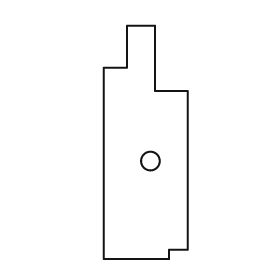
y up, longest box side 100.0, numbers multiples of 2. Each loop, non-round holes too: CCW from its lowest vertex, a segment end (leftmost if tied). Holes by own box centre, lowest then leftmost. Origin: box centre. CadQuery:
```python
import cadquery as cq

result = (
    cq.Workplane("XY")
    .moveTo(-18.0, -50.0)
    .lineTo(10.0, -50.0)
    .lineTo(10.0, -46.0)
    .lineTo(18.0, -46.0)
    .lineTo(18.0, 22.0)
    .lineTo(4.0, 22.0)
    .lineTo(4.0, 50.0)
    .lineTo(-8.0, 50.0)
    .lineTo(-8.0, 32.0)
    .lineTo(-18.0, 32.0)
    .close()
    .moveTo(2.0, -8.0)
    .circle(4.0)
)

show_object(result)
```